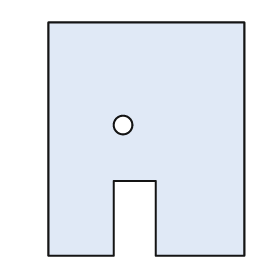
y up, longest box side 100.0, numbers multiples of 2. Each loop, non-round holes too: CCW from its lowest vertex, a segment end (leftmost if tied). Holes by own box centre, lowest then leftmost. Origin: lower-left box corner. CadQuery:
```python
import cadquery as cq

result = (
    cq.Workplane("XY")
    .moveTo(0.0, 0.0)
    .lineTo(28.0, 0.0)
    .lineTo(28.0, 32.0)
    .lineTo(46.0, 32.0)
    .lineTo(46.0, 0.0)
    .lineTo(84.0, 0.0)
    .lineTo(84.0, 100.0)
    .lineTo(0.0, 100.0)
    .close()
    .moveTo(32.0, 56.0)
    .circle(4.0)
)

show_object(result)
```